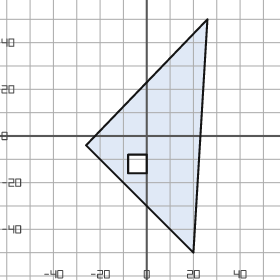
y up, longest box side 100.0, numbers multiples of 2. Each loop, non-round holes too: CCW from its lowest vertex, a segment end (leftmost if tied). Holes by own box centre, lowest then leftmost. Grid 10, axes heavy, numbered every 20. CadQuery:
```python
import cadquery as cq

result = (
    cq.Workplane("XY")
    .moveTo(20.0, -50.0)
    .lineTo(26.0, 50.0)
    .lineTo(-26.0, -4.0)
    .close()
    .moveTo(-8.0, -16.0)
    .lineTo(0.0, -16.0)
    .lineTo(0.0, -8.0)
    .lineTo(-8.0, -8.0)
    .close()
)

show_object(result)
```